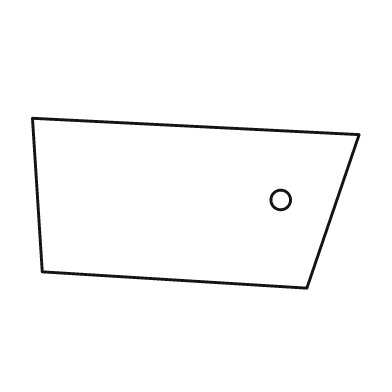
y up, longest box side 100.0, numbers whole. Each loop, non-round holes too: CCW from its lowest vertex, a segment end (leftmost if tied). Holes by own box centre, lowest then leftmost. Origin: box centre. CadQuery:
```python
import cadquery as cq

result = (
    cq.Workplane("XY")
    .moveTo(34.0, -26.0)
    .lineTo(50.0, 21.0)
    .lineTo(-50.0, 26.0)
    .lineTo(-47.0, -21.0)
    .close()
    .moveTo(26.0, 1.0)
    .circle(3.0)
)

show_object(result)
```